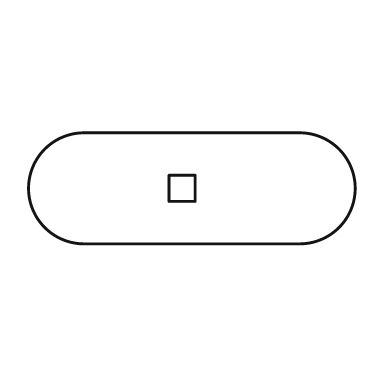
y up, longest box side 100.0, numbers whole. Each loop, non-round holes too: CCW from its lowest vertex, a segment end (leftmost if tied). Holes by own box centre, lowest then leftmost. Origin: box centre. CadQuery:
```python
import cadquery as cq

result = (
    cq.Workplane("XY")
    .moveTo(-33.0, -17.0)
    .lineTo(33.0, -17.0)
    .threePointArc((50.0, 0.0), (33.0, 17.0))
    .lineTo(-33.0, 17.0)
    .threePointArc((-50.0, 0.0), (-33.0, -17.0))
    .close()
    .moveTo(-7.0, -4.0)
    .lineTo(1.0, -4.0)
    .lineTo(1.0, 4.0)
    .lineTo(-7.0, 4.0)
    .close()
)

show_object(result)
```